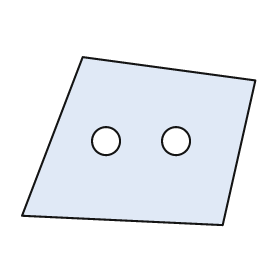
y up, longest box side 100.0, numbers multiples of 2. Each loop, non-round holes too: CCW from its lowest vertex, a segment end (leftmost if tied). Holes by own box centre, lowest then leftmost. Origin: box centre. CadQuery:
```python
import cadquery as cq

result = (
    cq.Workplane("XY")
    .moveTo(36.0, -36.0)
    .lineTo(50.0, 26.0)
    .lineTo(-24.0, 36.0)
    .lineTo(-50.0, -32.0)
    .close()
    .moveTo(-14.0, 0.0)
    .circle(6.0)
    .moveTo(16.0, 0.0)
    .circle(6.0)
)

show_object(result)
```